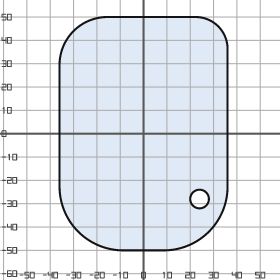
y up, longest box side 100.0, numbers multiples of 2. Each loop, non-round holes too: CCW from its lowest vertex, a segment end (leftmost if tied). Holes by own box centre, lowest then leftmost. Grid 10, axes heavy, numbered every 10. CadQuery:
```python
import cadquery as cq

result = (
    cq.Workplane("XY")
    .moveTo(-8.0, -50.0)
    .lineTo(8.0, -50.0)
    .threePointArc((28.0, -42.0), (36.0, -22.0))
    .lineTo(36.0, 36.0)
    .threePointArc((32.0, 46.0), (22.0, 50.0))
    .lineTo(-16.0, 50.0)
    .threePointArc((-30.0, 44.0), (-36.0, 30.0))
    .lineTo(-36.0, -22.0)
    .threePointArc((-28.0, -42.0), (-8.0, -50.0))
    .close()
    .moveTo(24.0, -28.0)
    .circle(4.0)
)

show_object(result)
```